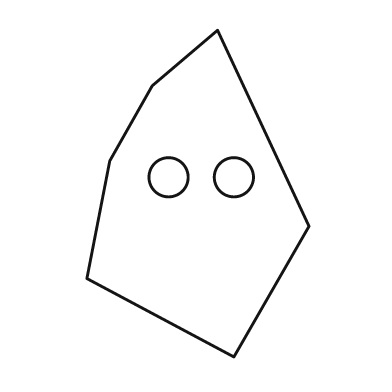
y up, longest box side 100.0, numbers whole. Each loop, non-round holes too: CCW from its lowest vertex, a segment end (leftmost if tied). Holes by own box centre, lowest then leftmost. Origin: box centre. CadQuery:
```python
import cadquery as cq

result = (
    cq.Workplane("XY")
    .moveTo(11.0, -50.0)
    .lineTo(34.0, -10.0)
    .lineTo(6.0, 50.0)
    .lineTo(-14.0, 33.0)
    .lineTo(-27.0, 10.0)
    .lineTo(-34.0, -26.0)
    .close()
    .moveTo(-9.0, 5.0)
    .circle(6.0)
    .moveTo(11.0, 5.0)
    .circle(6.0)
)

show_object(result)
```